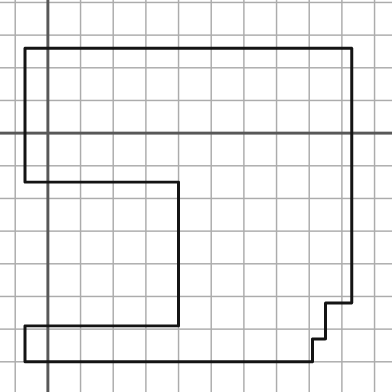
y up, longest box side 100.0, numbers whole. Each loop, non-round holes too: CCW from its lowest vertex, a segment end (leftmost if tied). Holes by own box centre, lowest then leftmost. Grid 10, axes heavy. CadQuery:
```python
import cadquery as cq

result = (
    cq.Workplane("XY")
    .moveTo(-7.0, -70.0)
    .lineTo(81.0, -70.0)
    .lineTo(81.0, -63.0)
    .lineTo(85.0, -63.0)
    .lineTo(85.0, -52.0)
    .lineTo(93.0, -52.0)
    .lineTo(93.0, 26.0)
    .lineTo(-7.0, 26.0)
    .lineTo(-7.0, -15.0)
    .lineTo(40.0, -15.0)
    .lineTo(40.0, -59.0)
    .lineTo(-7.0, -59.0)
    .close()
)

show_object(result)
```